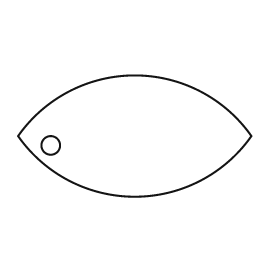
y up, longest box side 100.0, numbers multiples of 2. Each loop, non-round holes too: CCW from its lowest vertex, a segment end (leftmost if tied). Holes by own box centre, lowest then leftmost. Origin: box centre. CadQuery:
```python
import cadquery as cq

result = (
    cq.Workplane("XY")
    .moveTo(-50.0, 0.0)
    .threePointArc((0.0, -26.0), (50.0, 0.0))
    .threePointArc((0.0, 26.0), (-50.0, 0.0))
    .close()
    .moveTo(-36.0, -4.0)
    .circle(4.0)
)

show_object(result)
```